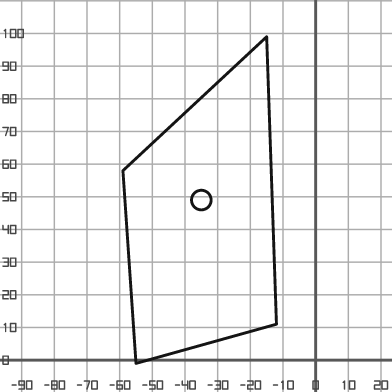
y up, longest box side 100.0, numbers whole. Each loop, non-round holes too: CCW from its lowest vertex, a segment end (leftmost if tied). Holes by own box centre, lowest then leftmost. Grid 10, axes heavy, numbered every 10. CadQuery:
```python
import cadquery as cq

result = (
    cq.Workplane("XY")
    .moveTo(-55.0, -1.0)
    .lineTo(-12.0, 11.0)
    .lineTo(-15.0, 99.0)
    .lineTo(-59.0, 58.0)
    .close()
    .moveTo(-35.0, 49.0)
    .circle(3.0)
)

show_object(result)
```